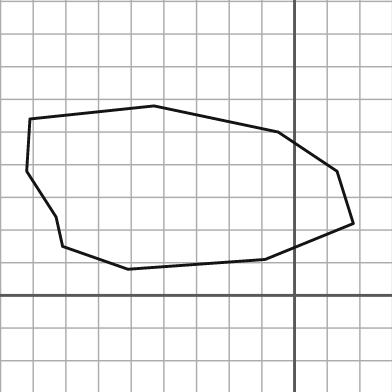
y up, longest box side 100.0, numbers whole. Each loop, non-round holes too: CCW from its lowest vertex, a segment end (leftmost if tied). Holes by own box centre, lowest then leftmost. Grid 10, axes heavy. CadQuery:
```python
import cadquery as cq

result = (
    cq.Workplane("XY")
    .moveTo(-51.0, 8.0)
    .lineTo(-9.0, 11.0)
    .lineTo(18.0, 22.0)
    .lineTo(13.0, 38.0)
    .lineTo(-5.0, 50.0)
    .lineTo(-43.0, 58.0)
    .lineTo(-81.0, 54.0)
    .lineTo(-82.0, 38.0)
    .lineTo(-73.0, 24.0)
    .lineTo(-71.0, 15.0)
    .close()
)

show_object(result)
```